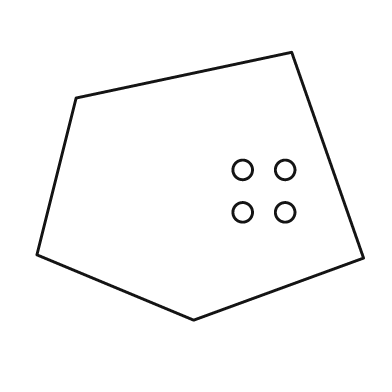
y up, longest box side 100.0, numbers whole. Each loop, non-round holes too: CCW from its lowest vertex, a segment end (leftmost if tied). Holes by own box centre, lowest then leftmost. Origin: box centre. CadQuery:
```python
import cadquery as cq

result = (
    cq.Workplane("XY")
    .moveTo(-2.0, -41.0)
    .lineTo(50.0, -22.0)
    .lineTo(28.0, 41.0)
    .lineTo(-38.0, 27.0)
    .lineTo(-50.0, -21.0)
    .close()
    .moveTo(13.0, -8.0)
    .circle(3.0)
    .moveTo(26.0, -8.0)
    .circle(3.0)
    .moveTo(13.0, 5.0)
    .circle(3.0)
    .moveTo(26.0, 5.0)
    .circle(3.0)
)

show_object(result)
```